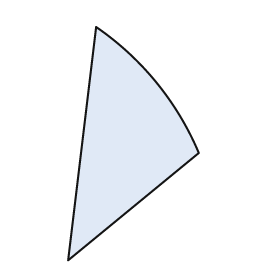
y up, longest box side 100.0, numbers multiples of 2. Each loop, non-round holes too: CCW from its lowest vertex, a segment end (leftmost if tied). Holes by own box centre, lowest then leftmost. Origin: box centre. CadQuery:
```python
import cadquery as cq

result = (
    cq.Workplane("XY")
    .moveTo(-28.0, -50.0)
    .lineTo(28.0, -4.0)
    .threePointArc((10.0, 26.0), (-16.0, 50.0))
    .close()
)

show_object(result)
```